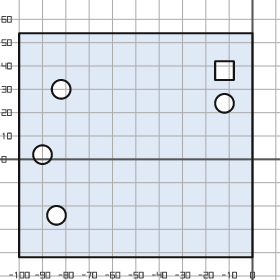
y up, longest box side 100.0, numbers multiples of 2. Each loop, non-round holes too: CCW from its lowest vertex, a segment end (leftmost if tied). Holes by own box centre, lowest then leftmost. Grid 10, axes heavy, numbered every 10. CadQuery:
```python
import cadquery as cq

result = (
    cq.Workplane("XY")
    .moveTo(-100.0, -42.0)
    .lineTo(0.0, -42.0)
    .lineTo(0.0, 54.0)
    .lineTo(-100.0, 54.0)
    .close()
    .moveTo(-84.0, -24.0)
    .circle(4.0)
    .moveTo(-90.0, 2.0)
    .circle(4.0)
    .moveTo(-12.0, 24.0)
    .circle(4.0)
    .moveTo(-82.0, 30.0)
    .circle(4.0)
    .moveTo(-16.0, 34.0)
    .lineTo(-8.0, 34.0)
    .lineTo(-8.0, 42.0)
    .lineTo(-16.0, 42.0)
    .close()
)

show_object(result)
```